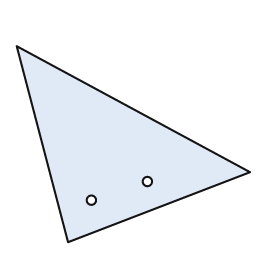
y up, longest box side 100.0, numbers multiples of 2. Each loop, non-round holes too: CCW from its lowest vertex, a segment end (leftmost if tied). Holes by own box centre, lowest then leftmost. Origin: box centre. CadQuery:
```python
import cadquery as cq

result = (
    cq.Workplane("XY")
    .moveTo(-28.0, -42.0)
    .lineTo(50.0, -12.0)
    .lineTo(-50.0, 42.0)
    .close()
    .moveTo(-18.0, -24.0)
    .circle(2.0)
    .moveTo(6.0, -16.0)
    .circle(2.0)
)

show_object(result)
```